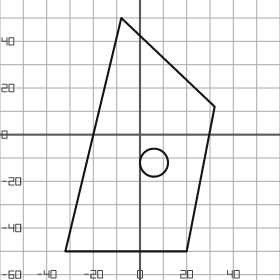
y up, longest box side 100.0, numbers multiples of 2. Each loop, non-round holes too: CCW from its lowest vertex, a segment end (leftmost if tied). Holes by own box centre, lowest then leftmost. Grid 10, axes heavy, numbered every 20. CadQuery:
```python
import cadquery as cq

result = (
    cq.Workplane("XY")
    .moveTo(-32.0, -50.0)
    .lineTo(20.0, -50.0)
    .lineTo(32.0, 12.0)
    .lineTo(-8.0, 50.0)
    .close()
    .moveTo(6.0, -12.0)
    .circle(6.0)
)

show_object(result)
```